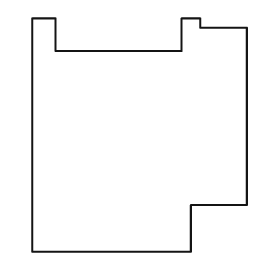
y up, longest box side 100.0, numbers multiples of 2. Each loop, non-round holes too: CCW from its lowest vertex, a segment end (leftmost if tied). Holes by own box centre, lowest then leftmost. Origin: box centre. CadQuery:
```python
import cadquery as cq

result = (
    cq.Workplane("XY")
    .moveTo(-46.0, -50.0)
    .lineTo(22.0, -50.0)
    .lineTo(22.0, -30.0)
    .lineTo(46.0, -30.0)
    .lineTo(46.0, 46.0)
    .lineTo(26.0, 46.0)
    .lineTo(26.0, 50.0)
    .lineTo(18.0, 50.0)
    .lineTo(18.0, 36.0)
    .lineTo(-36.0, 36.0)
    .lineTo(-36.0, 50.0)
    .lineTo(-46.0, 50.0)
    .close()
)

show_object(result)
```